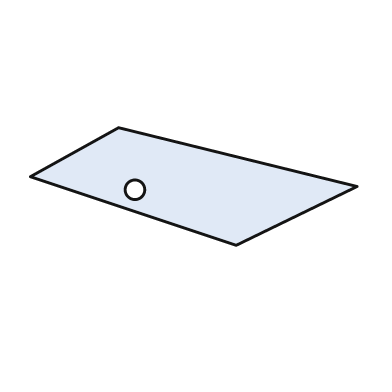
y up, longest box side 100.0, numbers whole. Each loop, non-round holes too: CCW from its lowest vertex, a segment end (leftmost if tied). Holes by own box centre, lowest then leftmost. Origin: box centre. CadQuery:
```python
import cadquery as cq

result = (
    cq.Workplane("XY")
    .moveTo(13.0, -18.0)
    .lineTo(50.0, 0.0)
    .lineTo(-23.0, 18.0)
    .lineTo(-50.0, 3.0)
    .close()
    .moveTo(-18.0, -1.0)
    .circle(3.0)
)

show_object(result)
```